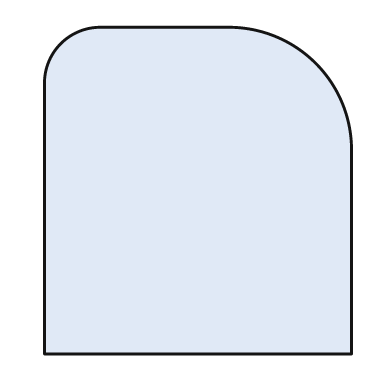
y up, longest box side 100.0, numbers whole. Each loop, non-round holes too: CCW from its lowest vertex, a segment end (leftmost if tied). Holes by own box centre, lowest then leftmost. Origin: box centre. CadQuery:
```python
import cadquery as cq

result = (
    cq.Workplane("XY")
    .moveTo(-47.0, -50.0)
    .lineTo(47.0, -50.0)
    .lineTo(47.0, 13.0)
    .threePointArc((36.0, 39.0), (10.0, 50.0))
    .lineTo(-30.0, 50.0)
    .threePointArc((-42.0, 45.0), (-47.0, 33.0))
    .close()
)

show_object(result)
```